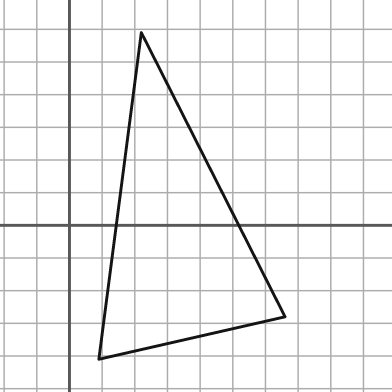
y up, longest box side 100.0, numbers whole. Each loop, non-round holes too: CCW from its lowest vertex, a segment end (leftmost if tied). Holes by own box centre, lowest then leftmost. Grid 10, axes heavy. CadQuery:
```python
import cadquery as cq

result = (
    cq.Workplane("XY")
    .moveTo(9.0, -41.0)
    .lineTo(66.0, -28.0)
    .lineTo(22.0, 59.0)
    .close()
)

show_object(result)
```